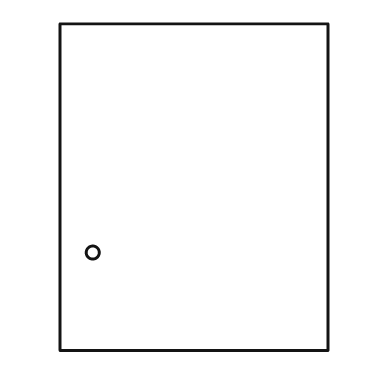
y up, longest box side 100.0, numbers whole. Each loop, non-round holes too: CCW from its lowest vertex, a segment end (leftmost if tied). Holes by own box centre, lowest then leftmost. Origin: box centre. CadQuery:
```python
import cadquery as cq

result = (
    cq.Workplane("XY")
    .moveTo(-41.0, -50.0)
    .lineTo(41.0, -50.0)
    .lineTo(41.0, 50.0)
    .lineTo(-41.0, 50.0)
    .close()
    .moveTo(-31.0, -20.0)
    .circle(2.0)
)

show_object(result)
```